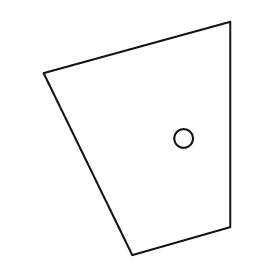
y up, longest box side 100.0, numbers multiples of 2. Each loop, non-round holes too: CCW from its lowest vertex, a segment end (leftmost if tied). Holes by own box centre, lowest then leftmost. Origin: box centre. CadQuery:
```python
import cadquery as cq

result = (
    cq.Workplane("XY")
    .moveTo(-2.0, -50.0)
    .lineTo(40.0, -38.0)
    .lineTo(40.0, 50.0)
    .lineTo(-40.0, 28.0)
    .close()
    .moveTo(20.0, 0.0)
    .circle(4.0)
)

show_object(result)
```